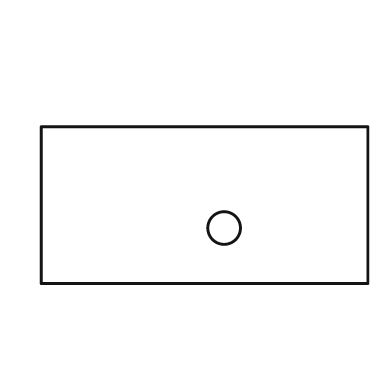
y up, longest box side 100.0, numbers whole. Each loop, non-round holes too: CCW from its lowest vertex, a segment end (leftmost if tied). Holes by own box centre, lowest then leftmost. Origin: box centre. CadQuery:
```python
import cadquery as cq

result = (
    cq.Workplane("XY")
    .moveTo(-50.0, -24.0)
    .lineTo(50.0, -24.0)
    .lineTo(50.0, 24.0)
    .lineTo(-50.0, 24.0)
    .close()
    .moveTo(6.0, -7.0)
    .circle(5.0)
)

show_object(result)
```